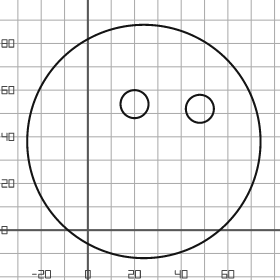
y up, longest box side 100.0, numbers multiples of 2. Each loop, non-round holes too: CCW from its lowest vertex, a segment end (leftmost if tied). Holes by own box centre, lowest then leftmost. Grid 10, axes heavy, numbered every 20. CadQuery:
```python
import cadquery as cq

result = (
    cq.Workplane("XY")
    .moveTo(24.0, 38.0)
    .circle(50.0)
    .moveTo(48.0, 52.0)
    .circle(6.0)
    .moveTo(20.0, 54.0)
    .circle(6.0)
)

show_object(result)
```